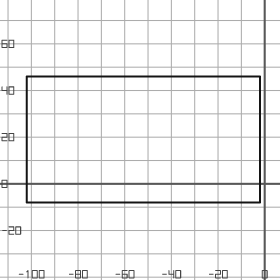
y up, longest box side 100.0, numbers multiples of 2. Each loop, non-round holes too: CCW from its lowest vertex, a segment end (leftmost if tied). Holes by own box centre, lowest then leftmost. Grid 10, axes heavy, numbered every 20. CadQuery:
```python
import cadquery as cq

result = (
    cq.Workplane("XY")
    .moveTo(-102.0, -8.0)
    .lineTo(-2.0, -8.0)
    .lineTo(-2.0, 46.0)
    .lineTo(-102.0, 46.0)
    .close()
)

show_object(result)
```